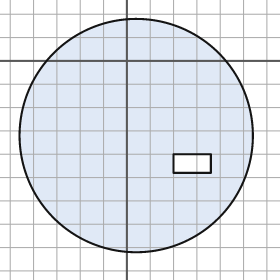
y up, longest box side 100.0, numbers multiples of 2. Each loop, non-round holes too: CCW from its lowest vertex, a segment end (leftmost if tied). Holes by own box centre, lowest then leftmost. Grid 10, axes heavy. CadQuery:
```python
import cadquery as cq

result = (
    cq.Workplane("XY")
    .moveTo(4.0, -32.0)
    .circle(50.0)
    .moveTo(20.0, -48.0)
    .lineTo(36.0, -48.0)
    .lineTo(36.0, -40.0)
    .lineTo(20.0, -40.0)
    .close()
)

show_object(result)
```